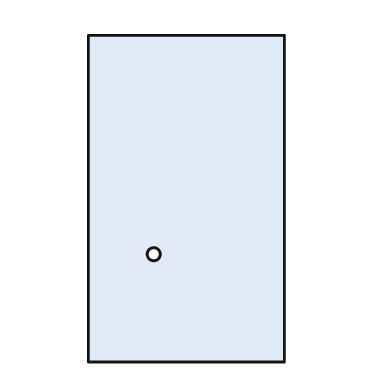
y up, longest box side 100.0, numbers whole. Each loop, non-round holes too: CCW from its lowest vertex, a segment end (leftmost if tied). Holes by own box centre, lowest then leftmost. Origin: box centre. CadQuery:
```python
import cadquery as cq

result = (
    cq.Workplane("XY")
    .moveTo(-30.0, -50.0)
    .lineTo(30.0, -50.0)
    .lineTo(30.0, 50.0)
    .lineTo(-30.0, 50.0)
    .close()
    .moveTo(-10.0, -17.0)
    .circle(2.0)
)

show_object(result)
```